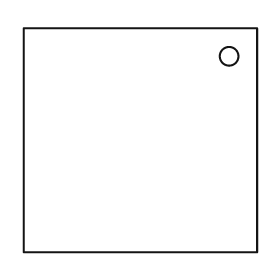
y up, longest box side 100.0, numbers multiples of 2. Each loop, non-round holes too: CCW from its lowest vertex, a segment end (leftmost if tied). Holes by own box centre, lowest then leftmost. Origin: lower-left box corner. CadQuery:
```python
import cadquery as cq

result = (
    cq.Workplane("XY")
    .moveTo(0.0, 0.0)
    .lineTo(100.0, 0.0)
    .lineTo(100.0, 96.0)
    .lineTo(0.0, 96.0)
    .close()
    .moveTo(88.0, 84.0)
    .circle(4.0)
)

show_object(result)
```